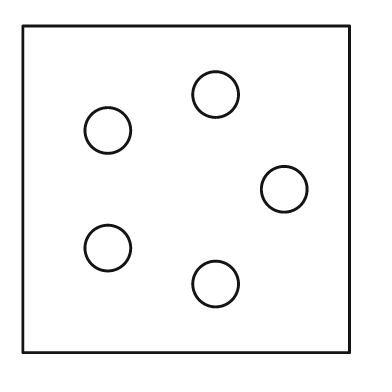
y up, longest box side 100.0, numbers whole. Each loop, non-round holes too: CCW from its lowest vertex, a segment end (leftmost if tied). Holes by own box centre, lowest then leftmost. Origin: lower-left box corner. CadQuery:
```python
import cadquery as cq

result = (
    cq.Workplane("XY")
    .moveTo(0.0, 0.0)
    .lineTo(100.0, 0.0)
    .lineTo(100.0, 100.0)
    .lineTo(0.0, 100.0)
    .close()
    .moveTo(59.0, 21.0)
    .circle(7.0)
    .moveTo(26.0, 32.0)
    .circle(7.0)
    .moveTo(80.0, 50.0)
    .circle(7.0)
    .moveTo(26.0, 68.0)
    .circle(7.0)
    .moveTo(59.0, 79.0)
    .circle(7.0)
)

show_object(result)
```